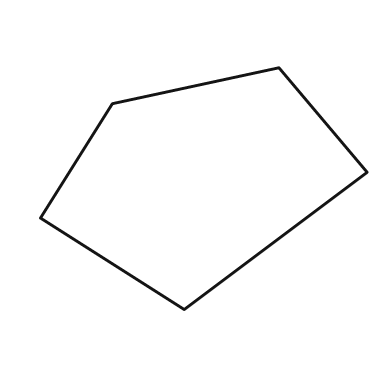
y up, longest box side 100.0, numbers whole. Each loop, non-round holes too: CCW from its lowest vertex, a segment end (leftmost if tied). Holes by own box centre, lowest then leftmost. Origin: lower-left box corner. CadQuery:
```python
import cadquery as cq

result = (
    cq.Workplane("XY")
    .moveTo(44.0, 0.0)
    .lineTo(100.0, 42.0)
    .lineTo(73.0, 74.0)
    .lineTo(22.0, 63.0)
    .lineTo(0.0, 28.0)
    .close()
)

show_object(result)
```